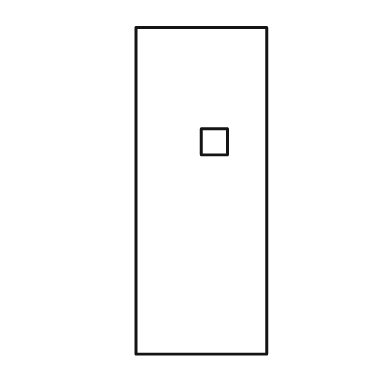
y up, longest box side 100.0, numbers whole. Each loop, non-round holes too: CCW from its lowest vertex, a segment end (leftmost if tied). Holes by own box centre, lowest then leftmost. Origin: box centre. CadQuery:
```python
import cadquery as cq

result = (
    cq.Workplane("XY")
    .moveTo(-20.0, -50.0)
    .lineTo(20.0, -50.0)
    .lineTo(20.0, 50.0)
    .lineTo(-20.0, 50.0)
    .close()
    .moveTo(0.0, 11.0)
    .lineTo(8.0, 11.0)
    .lineTo(8.0, 19.0)
    .lineTo(0.0, 19.0)
    .close()
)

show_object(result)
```